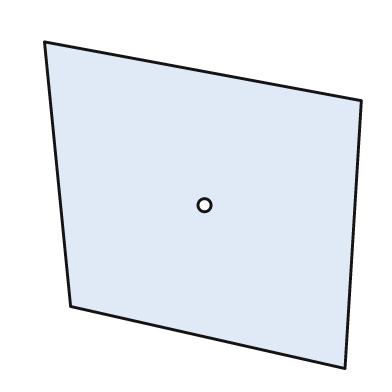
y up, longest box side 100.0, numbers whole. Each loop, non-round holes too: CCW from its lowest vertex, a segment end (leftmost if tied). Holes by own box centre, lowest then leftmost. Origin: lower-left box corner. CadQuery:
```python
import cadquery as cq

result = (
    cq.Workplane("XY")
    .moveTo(92.0, 0.0)
    .lineTo(97.0, 82.0)
    .lineTo(0.0, 100.0)
    .lineTo(8.0, 19.0)
    .close()
    .moveTo(49.0, 50.0)
    .circle(2.0)
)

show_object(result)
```